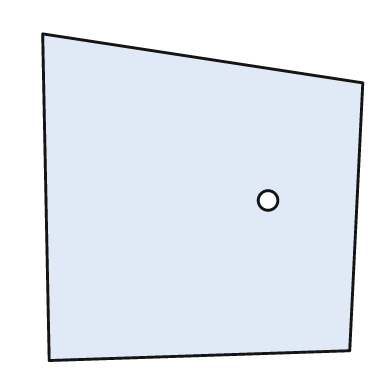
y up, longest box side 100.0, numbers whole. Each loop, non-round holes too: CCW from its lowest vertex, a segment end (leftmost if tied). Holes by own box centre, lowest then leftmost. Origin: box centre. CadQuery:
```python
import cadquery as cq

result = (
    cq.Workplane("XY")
    .moveTo(-47.0, -50.0)
    .lineTo(45.0, -47.0)
    .lineTo(49.0, 35.0)
    .lineTo(-49.0, 50.0)
    .close()
    .moveTo(20.0, -1.0)
    .circle(3.0)
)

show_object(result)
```